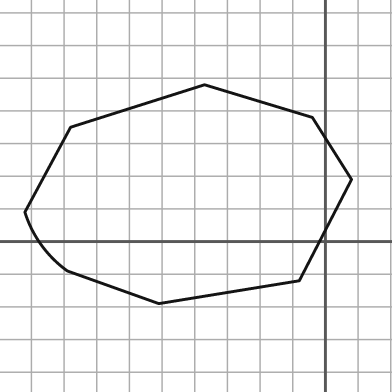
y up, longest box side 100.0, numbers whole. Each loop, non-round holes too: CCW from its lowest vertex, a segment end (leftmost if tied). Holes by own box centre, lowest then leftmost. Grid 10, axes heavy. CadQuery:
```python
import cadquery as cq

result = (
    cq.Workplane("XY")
    .moveTo(-51.0, -19.0)
    .lineTo(-8.0, -12.0)
    .lineTo(8.0, 19.0)
    .lineTo(-4.0, 38.0)
    .lineTo(-37.0, 48.0)
    .lineTo(-78.0, 35.0)
    .lineTo(-92.0, 9.0)
    .threePointArc((-87.0, -1.0), (-79.0, -9.0))
    .close()
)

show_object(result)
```